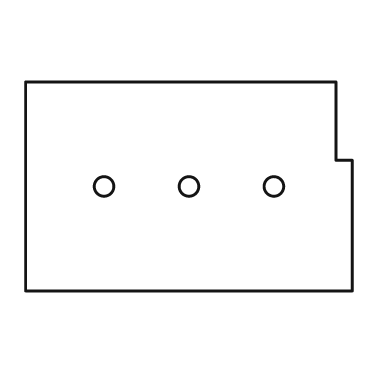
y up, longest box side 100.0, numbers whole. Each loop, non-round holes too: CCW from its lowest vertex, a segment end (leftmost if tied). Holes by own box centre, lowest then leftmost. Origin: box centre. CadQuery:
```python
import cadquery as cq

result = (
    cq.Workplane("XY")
    .moveTo(-50.0, -32.0)
    .lineTo(50.0, -32.0)
    .lineTo(50.0, 8.0)
    .lineTo(45.0, 8.0)
    .lineTo(45.0, 32.0)
    .lineTo(-50.0, 32.0)
    .close()
    .moveTo(-26.0, 0.0)
    .circle(3.0)
    .moveTo(0.0, 0.0)
    .circle(3.0)
    .moveTo(26.0, 0.0)
    .circle(3.0)
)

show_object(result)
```